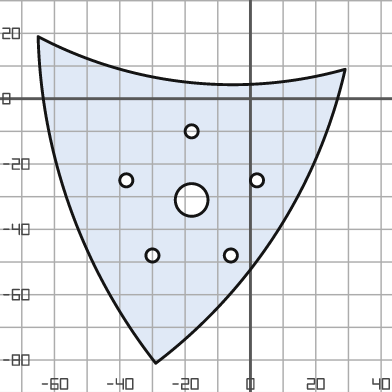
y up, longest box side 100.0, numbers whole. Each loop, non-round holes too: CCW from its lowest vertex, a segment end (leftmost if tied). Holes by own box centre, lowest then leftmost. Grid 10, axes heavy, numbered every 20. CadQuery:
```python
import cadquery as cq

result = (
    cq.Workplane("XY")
    .moveTo(-29.0, -81.0)
    .threePointArc((8.0, -41.0), (29.0, 9.0))
    .threePointArc((-19.0, 5.0), (-65.0, 19.0))
    .threePointArc((-55.0, -34.0), (-29.0, -81.0))
    .close()
    .moveTo(-30.0, -48.0)
    .circle(2.0)
    .moveTo(-6.0, -48.0)
    .circle(2.0)
    .moveTo(-18.0, -31.0)
    .circle(5.0)
    .moveTo(-38.0, -25.0)
    .circle(2.0)
    .moveTo(2.0, -25.0)
    .circle(2.0)
    .moveTo(-18.0, -10.0)
    .circle(2.0)
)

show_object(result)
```